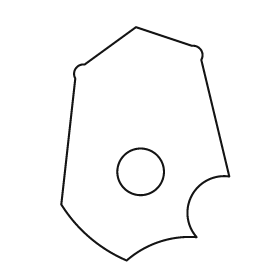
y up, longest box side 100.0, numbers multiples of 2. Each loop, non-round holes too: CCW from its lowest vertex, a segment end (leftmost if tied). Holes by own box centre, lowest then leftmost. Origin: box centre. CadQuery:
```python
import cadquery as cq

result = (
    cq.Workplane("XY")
    .moveTo(-8.0, -50.0)
    .threePointArc((6.0, -42.0), (22.0, -40.0))
    .threePointArc((20.0, -22.0), (36.0, -14.0))
    .lineTo(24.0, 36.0)
    .threePointArc((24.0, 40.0), (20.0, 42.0))
    .lineTo(-4.0, 50.0)
    .lineTo(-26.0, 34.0)
    .threePointArc((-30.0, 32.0), (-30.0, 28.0))
    .lineTo(-36.0, -26.0)
    .threePointArc((-24.0, -40.0), (-8.0, -50.0))
    .close()
    .moveTo(-2.0, -12.0)
    .circle(10.0)
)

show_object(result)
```